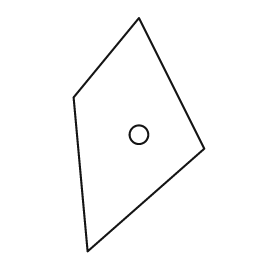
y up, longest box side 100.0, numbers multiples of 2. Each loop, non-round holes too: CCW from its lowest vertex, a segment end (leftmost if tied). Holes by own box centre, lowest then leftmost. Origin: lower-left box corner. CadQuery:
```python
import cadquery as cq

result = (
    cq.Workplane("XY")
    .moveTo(6.0, 0.0)
    .lineTo(56.0, 44.0)
    .lineTo(28.0, 100.0)
    .lineTo(0.0, 66.0)
    .close()
    .moveTo(28.0, 50.0)
    .circle(4.0)
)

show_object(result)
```